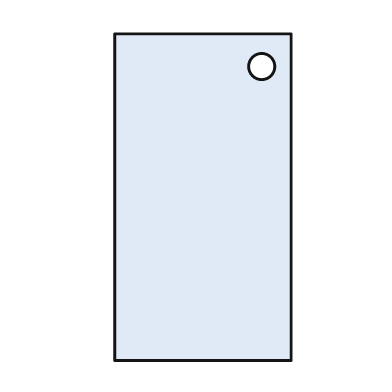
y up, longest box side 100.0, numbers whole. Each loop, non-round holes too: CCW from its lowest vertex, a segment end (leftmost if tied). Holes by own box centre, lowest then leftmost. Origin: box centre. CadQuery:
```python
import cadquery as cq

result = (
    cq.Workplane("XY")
    .moveTo(-27.0, -50.0)
    .lineTo(27.0, -50.0)
    .lineTo(27.0, 50.0)
    .lineTo(-27.0, 50.0)
    .close()
    .moveTo(18.0, 40.0)
    .circle(4.0)
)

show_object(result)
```